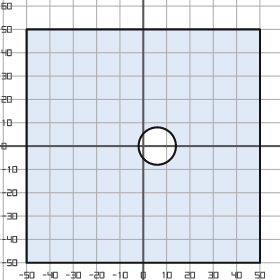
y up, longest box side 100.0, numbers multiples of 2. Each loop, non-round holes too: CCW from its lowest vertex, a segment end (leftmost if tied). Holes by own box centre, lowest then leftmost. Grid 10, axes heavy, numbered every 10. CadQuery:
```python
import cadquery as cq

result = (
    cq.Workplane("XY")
    .moveTo(-50.0, -50.0)
    .lineTo(50.0, -50.0)
    .lineTo(50.0, 50.0)
    .lineTo(-50.0, 50.0)
    .close()
    .moveTo(6.0, 0.0)
    .circle(8.0)
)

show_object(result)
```